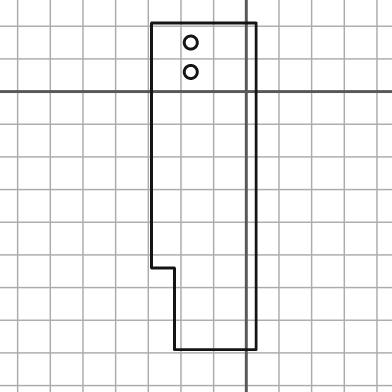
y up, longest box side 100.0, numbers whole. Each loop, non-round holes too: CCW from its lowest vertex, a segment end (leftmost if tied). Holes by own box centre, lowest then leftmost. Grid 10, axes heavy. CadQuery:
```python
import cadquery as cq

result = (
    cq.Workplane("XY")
    .moveTo(-22.0, -79.0)
    .lineTo(3.0, -79.0)
    .lineTo(3.0, 21.0)
    .lineTo(-29.0, 21.0)
    .lineTo(-29.0, -54.0)
    .lineTo(-22.0, -54.0)
    .close()
    .moveTo(-17.0, 6.0)
    .circle(2.0)
    .moveTo(-17.0, 15.0)
    .circle(2.0)
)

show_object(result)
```